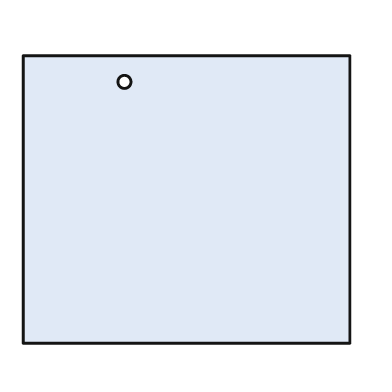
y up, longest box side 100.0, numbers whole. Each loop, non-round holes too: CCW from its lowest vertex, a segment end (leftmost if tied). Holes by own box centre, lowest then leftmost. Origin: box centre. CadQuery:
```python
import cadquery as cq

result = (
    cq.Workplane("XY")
    .moveTo(-50.0, -44.0)
    .lineTo(50.0, -44.0)
    .lineTo(50.0, 44.0)
    .lineTo(-50.0, 44.0)
    .close()
    .moveTo(-19.0, 36.0)
    .circle(2.0)
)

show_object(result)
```